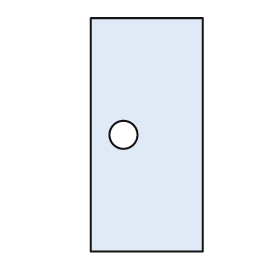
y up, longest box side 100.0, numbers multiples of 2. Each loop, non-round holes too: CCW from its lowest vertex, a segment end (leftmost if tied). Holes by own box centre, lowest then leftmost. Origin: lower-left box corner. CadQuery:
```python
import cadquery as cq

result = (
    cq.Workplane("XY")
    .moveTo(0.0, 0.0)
    .lineTo(48.0, 0.0)
    .lineTo(48.0, 100.0)
    .lineTo(0.0, 100.0)
    .close()
    .moveTo(14.0, 50.0)
    .circle(6.0)
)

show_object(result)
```